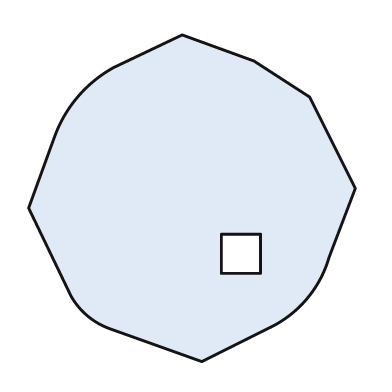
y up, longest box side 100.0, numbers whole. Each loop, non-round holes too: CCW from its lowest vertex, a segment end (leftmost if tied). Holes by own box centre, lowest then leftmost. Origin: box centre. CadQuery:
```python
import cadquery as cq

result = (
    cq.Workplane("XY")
    .moveTo(3.0, -50.0)
    .lineTo(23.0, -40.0)
    .threePointArc((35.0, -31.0), (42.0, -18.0))
    .lineTo(50.0, 3.0)
    .lineTo(36.0, 31.0)
    .lineTo(19.0, 42.0)
    .lineTo(-3.0, 50.0)
    .lineTo(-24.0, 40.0)
    .threePointArc((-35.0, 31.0), (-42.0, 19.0))
    .lineTo(-50.0, -3.0)
    .lineTo(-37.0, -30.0)
    .threePointArc((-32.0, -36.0), (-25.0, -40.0))
    .close()
    .moveTo(9.0, -23.0)
    .lineTo(21.0, -23.0)
    .lineTo(21.0, -11.0)
    .lineTo(9.0, -11.0)
    .close()
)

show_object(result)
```